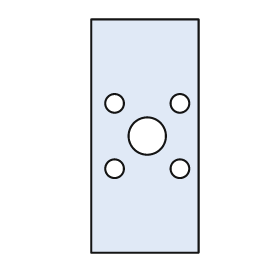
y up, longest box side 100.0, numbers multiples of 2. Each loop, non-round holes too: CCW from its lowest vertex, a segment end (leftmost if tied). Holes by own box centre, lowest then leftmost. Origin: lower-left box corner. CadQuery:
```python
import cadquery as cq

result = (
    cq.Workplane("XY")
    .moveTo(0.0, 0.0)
    .lineTo(46.0, 0.0)
    .lineTo(46.0, 100.0)
    .lineTo(0.0, 100.0)
    .close()
    .moveTo(10.0, 36.0)
    .circle(4.0)
    .moveTo(38.0, 36.0)
    .circle(4.0)
    .moveTo(24.0, 50.0)
    .circle(8.0)
    .moveTo(10.0, 64.0)
    .circle(4.0)
    .moveTo(38.0, 64.0)
    .circle(4.0)
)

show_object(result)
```